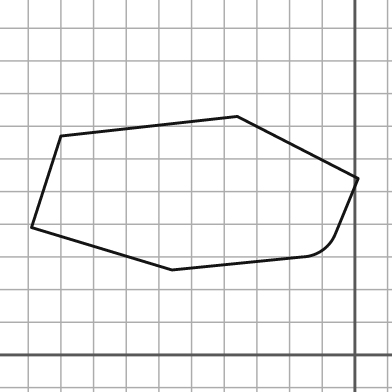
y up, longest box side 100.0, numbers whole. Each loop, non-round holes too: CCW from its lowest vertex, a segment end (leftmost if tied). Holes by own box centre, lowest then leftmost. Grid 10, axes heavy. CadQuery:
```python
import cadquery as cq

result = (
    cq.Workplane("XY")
    .moveTo(-56.0, 26.0)
    .lineTo(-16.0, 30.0)
    .threePointArc((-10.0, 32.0), (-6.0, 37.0))
    .lineTo(1.0, 54.0)
    .lineTo(-36.0, 73.0)
    .lineTo(-90.0, 67.0)
    .lineTo(-99.0, 39.0)
    .close()
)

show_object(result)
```